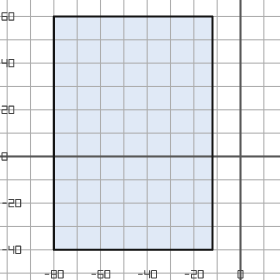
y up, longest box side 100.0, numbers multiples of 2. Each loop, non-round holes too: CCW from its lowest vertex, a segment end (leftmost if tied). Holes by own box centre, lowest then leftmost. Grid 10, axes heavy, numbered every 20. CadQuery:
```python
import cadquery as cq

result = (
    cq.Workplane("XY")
    .moveTo(-80.0, -40.0)
    .lineTo(-12.0, -40.0)
    .lineTo(-12.0, 60.0)
    .lineTo(-80.0, 60.0)
    .close()
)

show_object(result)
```